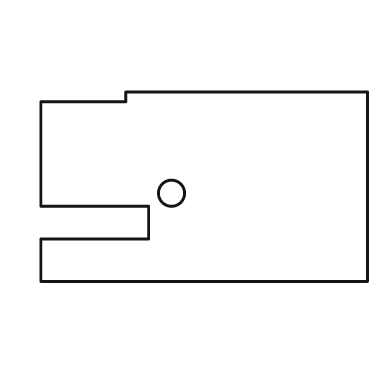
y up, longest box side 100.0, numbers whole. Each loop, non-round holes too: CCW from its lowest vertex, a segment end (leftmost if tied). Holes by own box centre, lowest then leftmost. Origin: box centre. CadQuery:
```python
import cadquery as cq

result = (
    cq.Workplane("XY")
    .moveTo(-50.0, -29.0)
    .lineTo(50.0, -29.0)
    .lineTo(50.0, 29.0)
    .lineTo(-24.0, 29.0)
    .lineTo(-24.0, 26.0)
    .lineTo(-50.0, 26.0)
    .lineTo(-50.0, -6.0)
    .lineTo(-17.0, -6.0)
    .lineTo(-17.0, -16.0)
    .lineTo(-50.0, -16.0)
    .close()
    .moveTo(-10.0, -2.0)
    .circle(4.0)
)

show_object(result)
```